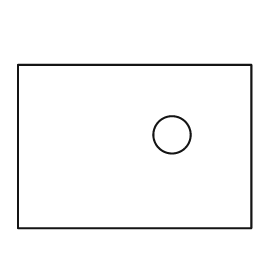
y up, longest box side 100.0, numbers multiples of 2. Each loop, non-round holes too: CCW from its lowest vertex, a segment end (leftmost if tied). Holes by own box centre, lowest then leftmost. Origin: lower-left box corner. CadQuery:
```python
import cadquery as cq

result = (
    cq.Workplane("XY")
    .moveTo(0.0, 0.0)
    .lineTo(100.0, 0.0)
    .lineTo(100.0, 70.0)
    .lineTo(0.0, 70.0)
    .close()
    .moveTo(66.0, 40.0)
    .circle(8.0)
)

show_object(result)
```